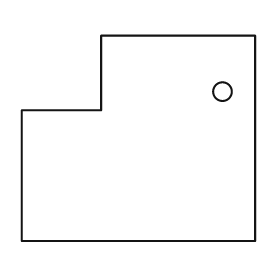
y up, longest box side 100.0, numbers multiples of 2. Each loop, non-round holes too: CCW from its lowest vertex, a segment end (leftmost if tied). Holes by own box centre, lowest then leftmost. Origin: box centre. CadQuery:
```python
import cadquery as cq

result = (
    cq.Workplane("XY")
    .moveTo(-50.0, -44.0)
    .lineTo(50.0, -44.0)
    .lineTo(50.0, 44.0)
    .lineTo(-16.0, 44.0)
    .lineTo(-16.0, 12.0)
    .lineTo(-50.0, 12.0)
    .close()
    .moveTo(36.0, 20.0)
    .circle(4.0)
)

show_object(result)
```